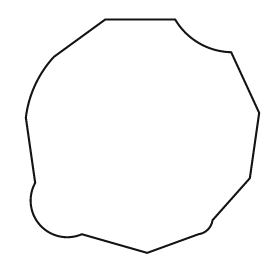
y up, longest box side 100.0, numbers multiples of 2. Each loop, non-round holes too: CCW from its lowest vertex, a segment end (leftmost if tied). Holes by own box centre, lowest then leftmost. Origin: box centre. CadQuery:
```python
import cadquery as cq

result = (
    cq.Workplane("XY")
    .moveTo(2.0, -50.0)
    .lineTo(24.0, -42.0)
    .threePointArc((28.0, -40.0), (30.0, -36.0))
    .lineTo(46.0, -18.0)
    .lineTo(50.0, 10.0)
    .lineTo(38.0, 36.0)
    .threePointArc((24.0, 40.0), (14.0, 50.0))
    .lineTo(-16.0, 50.0)
    .lineTo(-38.0, 34.0)
    .threePointArc((-46.0, 22.0), (-50.0, 8.0))
    .lineTo(-46.0, -20.0)
    .threePointArc((-44.0, -38.0), (-26.0, -42.0))
    .close()
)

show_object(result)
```